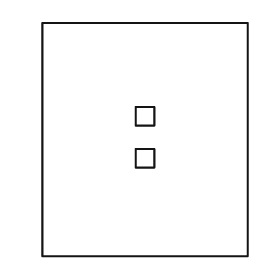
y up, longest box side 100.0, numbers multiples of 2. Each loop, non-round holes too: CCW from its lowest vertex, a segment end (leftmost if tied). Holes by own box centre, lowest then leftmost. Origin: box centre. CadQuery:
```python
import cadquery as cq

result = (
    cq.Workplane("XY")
    .moveTo(-44.0, -50.0)
    .lineTo(44.0, -50.0)
    .lineTo(44.0, 50.0)
    .lineTo(-44.0, 50.0)
    .close()
    .moveTo(-4.0, -12.0)
    .lineTo(4.0, -12.0)
    .lineTo(4.0, -4.0)
    .lineTo(-4.0, -4.0)
    .close()
    .moveTo(-4.0, 6.0)
    .lineTo(4.0, 6.0)
    .lineTo(4.0, 14.0)
    .lineTo(-4.0, 14.0)
    .close()
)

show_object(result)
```